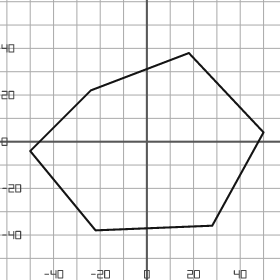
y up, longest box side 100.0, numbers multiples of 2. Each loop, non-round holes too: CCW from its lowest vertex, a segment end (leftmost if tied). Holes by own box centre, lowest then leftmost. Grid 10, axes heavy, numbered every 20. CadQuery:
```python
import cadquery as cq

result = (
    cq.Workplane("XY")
    .moveTo(-22.0, -38.0)
    .lineTo(28.0, -36.0)
    .lineTo(50.0, 4.0)
    .lineTo(18.0, 38.0)
    .lineTo(-24.0, 22.0)
    .lineTo(-50.0, -4.0)
    .close()
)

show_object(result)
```